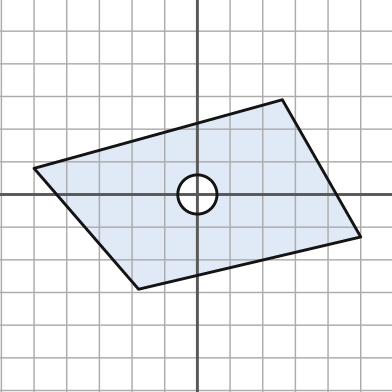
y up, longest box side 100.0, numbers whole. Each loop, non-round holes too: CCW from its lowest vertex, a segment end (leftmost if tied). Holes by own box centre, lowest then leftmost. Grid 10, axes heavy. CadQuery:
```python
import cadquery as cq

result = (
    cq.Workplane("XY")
    .moveTo(-18.0, -29.0)
    .lineTo(50.0, -13.0)
    .lineTo(26.0, 29.0)
    .lineTo(-50.0, 8.0)
    .close()
    .moveTo(0.0, 0.0)
    .circle(6.0)
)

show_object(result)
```